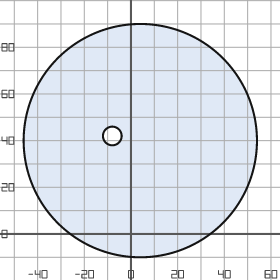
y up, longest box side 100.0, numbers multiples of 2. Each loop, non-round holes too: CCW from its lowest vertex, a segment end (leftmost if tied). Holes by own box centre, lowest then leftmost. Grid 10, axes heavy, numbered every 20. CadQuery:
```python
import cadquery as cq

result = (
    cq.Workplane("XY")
    .moveTo(4.0, 40.0)
    .circle(50.0)
    .moveTo(-8.0, 42.0)
    .circle(4.0)
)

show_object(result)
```